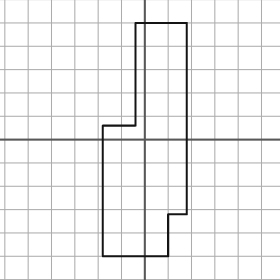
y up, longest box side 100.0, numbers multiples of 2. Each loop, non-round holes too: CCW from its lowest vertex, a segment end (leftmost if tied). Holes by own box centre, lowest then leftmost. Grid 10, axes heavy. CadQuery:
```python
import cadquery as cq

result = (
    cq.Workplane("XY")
    .moveTo(-18.0, -50.0)
    .lineTo(10.0, -50.0)
    .lineTo(10.0, -32.0)
    .lineTo(18.0, -32.0)
    .lineTo(18.0, 50.0)
    .lineTo(-4.0, 50.0)
    .lineTo(-4.0, 6.0)
    .lineTo(-18.0, 6.0)
    .close()
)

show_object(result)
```